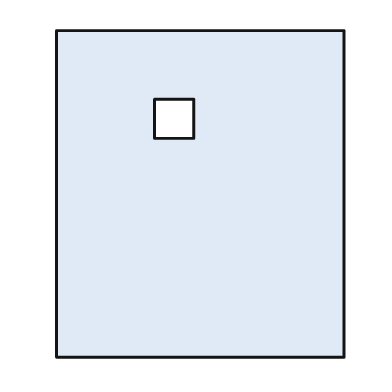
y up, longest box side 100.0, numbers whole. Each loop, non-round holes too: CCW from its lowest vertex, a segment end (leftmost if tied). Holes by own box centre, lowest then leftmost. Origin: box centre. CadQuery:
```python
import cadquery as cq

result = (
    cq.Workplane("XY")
    .moveTo(-44.0, -50.0)
    .lineTo(44.0, -50.0)
    .lineTo(44.0, 50.0)
    .lineTo(-44.0, 50.0)
    .close()
    .moveTo(-14.0, 17.0)
    .lineTo(-2.0, 17.0)
    .lineTo(-2.0, 29.0)
    .lineTo(-14.0, 29.0)
    .close()
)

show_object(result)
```